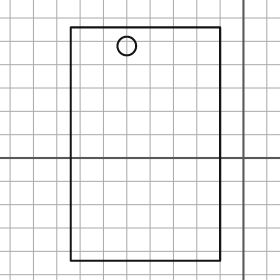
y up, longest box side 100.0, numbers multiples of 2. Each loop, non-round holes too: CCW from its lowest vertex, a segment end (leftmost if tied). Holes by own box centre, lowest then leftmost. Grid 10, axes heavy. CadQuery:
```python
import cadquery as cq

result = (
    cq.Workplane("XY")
    .moveTo(-74.0, -44.0)
    .lineTo(-10.0, -44.0)
    .lineTo(-10.0, 56.0)
    .lineTo(-74.0, 56.0)
    .close()
    .moveTo(-50.0, 48.0)
    .circle(4.0)
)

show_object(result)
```